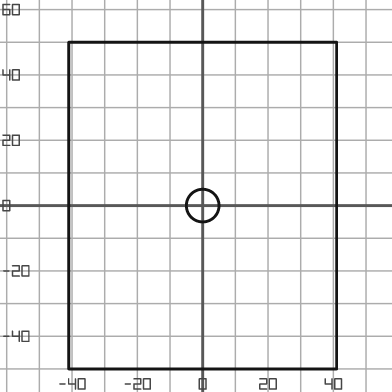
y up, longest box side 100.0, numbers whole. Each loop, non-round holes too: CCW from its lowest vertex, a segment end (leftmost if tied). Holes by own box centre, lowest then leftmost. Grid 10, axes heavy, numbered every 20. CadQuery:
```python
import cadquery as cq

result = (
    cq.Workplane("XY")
    .moveTo(-41.0, -50.0)
    .lineTo(41.0, -50.0)
    .lineTo(41.0, 50.0)
    .lineTo(-41.0, 50.0)
    .close()
    .moveTo(0.0, 0.0)
    .circle(5.0)
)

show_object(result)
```